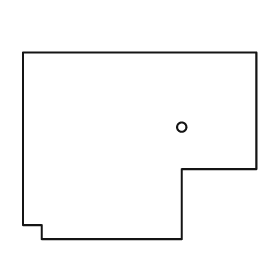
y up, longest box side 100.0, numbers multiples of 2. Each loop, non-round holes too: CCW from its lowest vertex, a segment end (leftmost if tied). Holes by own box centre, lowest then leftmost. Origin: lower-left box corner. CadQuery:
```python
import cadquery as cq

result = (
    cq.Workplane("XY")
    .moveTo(8.0, 0.0)
    .lineTo(68.0, 0.0)
    .lineTo(68.0, 30.0)
    .lineTo(100.0, 30.0)
    .lineTo(100.0, 80.0)
    .lineTo(0.0, 80.0)
    .lineTo(0.0, 6.0)
    .lineTo(8.0, 6.0)
    .close()
    .moveTo(68.0, 48.0)
    .circle(2.0)
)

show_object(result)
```